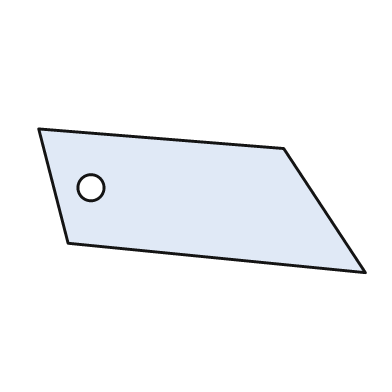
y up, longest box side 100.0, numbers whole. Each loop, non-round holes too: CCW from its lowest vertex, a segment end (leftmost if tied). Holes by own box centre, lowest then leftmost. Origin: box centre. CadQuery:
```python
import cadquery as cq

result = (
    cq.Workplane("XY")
    .moveTo(50.0, -22.0)
    .lineTo(25.0, 16.0)
    .lineTo(-50.0, 22.0)
    .lineTo(-41.0, -13.0)
    .close()
    .moveTo(-34.0, 4.0)
    .circle(4.0)
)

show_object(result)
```